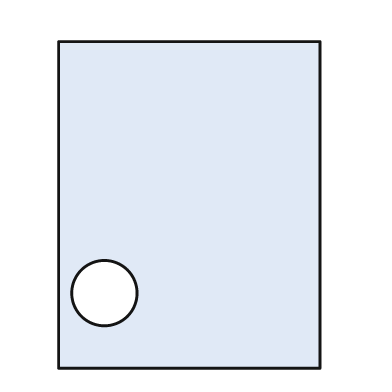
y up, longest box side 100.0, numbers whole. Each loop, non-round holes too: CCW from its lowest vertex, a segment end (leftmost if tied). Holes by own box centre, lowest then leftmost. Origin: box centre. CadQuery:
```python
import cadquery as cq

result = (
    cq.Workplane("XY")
    .moveTo(-40.0, -50.0)
    .lineTo(40.0, -50.0)
    .lineTo(40.0, 50.0)
    .lineTo(-40.0, 50.0)
    .close()
    .moveTo(-26.0, -27.0)
    .circle(10.0)
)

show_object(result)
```